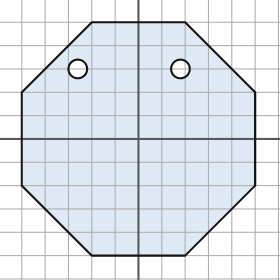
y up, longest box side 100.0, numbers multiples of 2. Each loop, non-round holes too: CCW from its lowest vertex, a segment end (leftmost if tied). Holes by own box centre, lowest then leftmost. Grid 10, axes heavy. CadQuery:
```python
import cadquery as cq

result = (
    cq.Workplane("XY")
    .moveTo(-20.0, -50.0)
    .lineTo(20.0, -50.0)
    .lineTo(50.0, -20.0)
    .lineTo(50.0, 20.0)
    .lineTo(20.0, 50.0)
    .lineTo(-20.0, 50.0)
    .lineTo(-50.0, 20.0)
    .lineTo(-50.0, -20.0)
    .close()
    .moveTo(-26.0, 30.0)
    .circle(4.0)
    .moveTo(18.0, 30.0)
    .circle(4.0)
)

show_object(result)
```